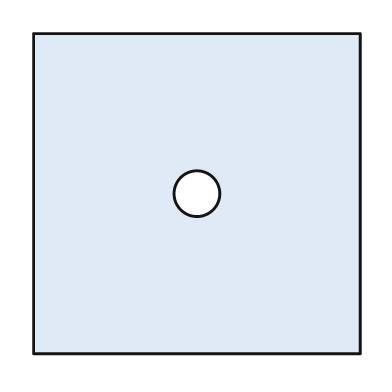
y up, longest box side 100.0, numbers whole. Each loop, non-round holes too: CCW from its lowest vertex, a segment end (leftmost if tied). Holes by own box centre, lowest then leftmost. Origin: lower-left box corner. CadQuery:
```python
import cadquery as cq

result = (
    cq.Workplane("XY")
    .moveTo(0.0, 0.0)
    .lineTo(100.0, 0.0)
    .lineTo(100.0, 98.0)
    .lineTo(0.0, 98.0)
    .close()
    .moveTo(50.0, 49.0)
    .circle(7.0)
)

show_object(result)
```